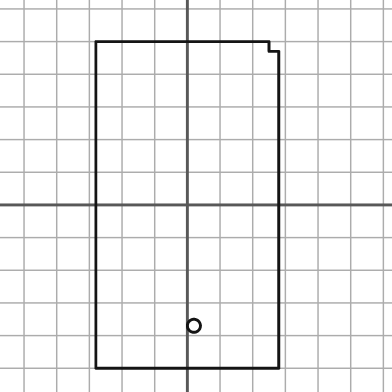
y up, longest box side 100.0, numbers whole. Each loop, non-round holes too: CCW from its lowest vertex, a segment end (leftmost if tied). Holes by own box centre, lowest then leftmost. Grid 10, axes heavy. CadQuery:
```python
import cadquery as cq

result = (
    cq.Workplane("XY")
    .moveTo(-28.0, -50.0)
    .lineTo(28.0, -50.0)
    .lineTo(28.0, 47.0)
    .lineTo(25.0, 47.0)
    .lineTo(25.0, 50.0)
    .lineTo(-28.0, 50.0)
    .close()
    .moveTo(2.0, -37.0)
    .circle(2.0)
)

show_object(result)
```